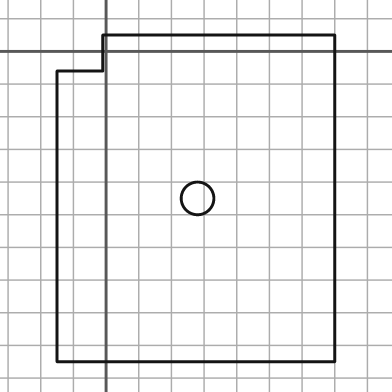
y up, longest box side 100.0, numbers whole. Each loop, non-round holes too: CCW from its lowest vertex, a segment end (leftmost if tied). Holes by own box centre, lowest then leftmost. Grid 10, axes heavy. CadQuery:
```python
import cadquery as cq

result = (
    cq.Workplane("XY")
    .moveTo(-15.0, -95.0)
    .lineTo(70.0, -95.0)
    .lineTo(70.0, 5.0)
    .lineTo(-1.0, 5.0)
    .lineTo(-1.0, -6.0)
    .lineTo(-15.0, -6.0)
    .close()
    .moveTo(28.0, -45.0)
    .circle(5.0)
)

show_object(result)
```